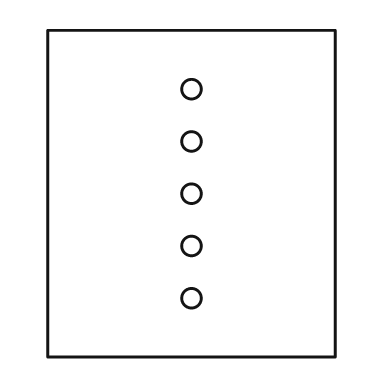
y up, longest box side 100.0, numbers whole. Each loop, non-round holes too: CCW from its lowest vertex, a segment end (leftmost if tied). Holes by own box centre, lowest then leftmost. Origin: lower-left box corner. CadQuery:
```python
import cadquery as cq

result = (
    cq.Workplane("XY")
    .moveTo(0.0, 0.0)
    .lineTo(88.0, 0.0)
    .lineTo(88.0, 100.0)
    .lineTo(0.0, 100.0)
    .close()
    .moveTo(44.0, 18.0)
    .circle(3.0)
    .moveTo(44.0, 34.0)
    .circle(3.0)
    .moveTo(44.0, 50.0)
    .circle(3.0)
    .moveTo(44.0, 66.0)
    .circle(3.0)
    .moveTo(44.0, 82.0)
    .circle(3.0)
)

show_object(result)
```